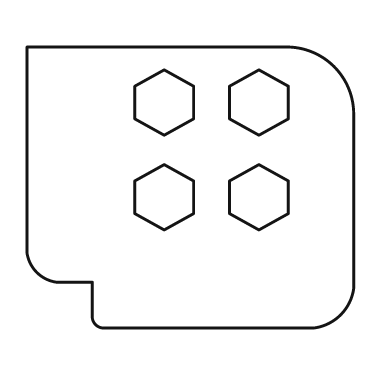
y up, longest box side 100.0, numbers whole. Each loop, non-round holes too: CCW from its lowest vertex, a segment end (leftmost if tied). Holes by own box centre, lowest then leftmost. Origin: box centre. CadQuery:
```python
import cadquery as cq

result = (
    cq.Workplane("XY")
    .moveTo(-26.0, -43.0)
    .lineTo(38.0, -43.0)
    .threePointArc((46.0, -39.0), (50.0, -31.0))
    .lineTo(50.0, 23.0)
    .threePointArc((44.0, 37.0), (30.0, 43.0))
    .lineTo(-50.0, 43.0)
    .lineTo(-50.0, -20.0)
    .threePointArc((-47.0, -26.0), (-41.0, -29.0))
    .lineTo(-30.0, -29.0)
    .lineTo(-30.0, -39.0)
    .threePointArc((-29.0, -42.0), (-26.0, -43.0))
    .close()
    .moveTo(-8.0, -13.0)
    .lineTo(1.0, -8.0)
    .lineTo(1.0, 2.0)
    .lineTo(-8.0, 7.0)
    .lineTo(-17.0, 2.0)
    .lineTo(-17.0, -8.0)
    .close()
    .moveTo(21.0, -13.0)
    .lineTo(30.0, -8.0)
    .lineTo(30.0, 2.0)
    .lineTo(21.0, 7.0)
    .lineTo(12.0, 2.0)
    .lineTo(12.0, -8.0)
    .close()
    .moveTo(-8.0, 16.0)
    .lineTo(1.0, 21.0)
    .lineTo(1.0, 31.0)
    .lineTo(-8.0, 36.0)
    .lineTo(-17.0, 31.0)
    .lineTo(-17.0, 21.0)
    .close()
    .moveTo(21.0, 16.0)
    .lineTo(30.0, 21.0)
    .lineTo(30.0, 31.0)
    .lineTo(21.0, 36.0)
    .lineTo(12.0, 31.0)
    .lineTo(12.0, 21.0)
    .close()
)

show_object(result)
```